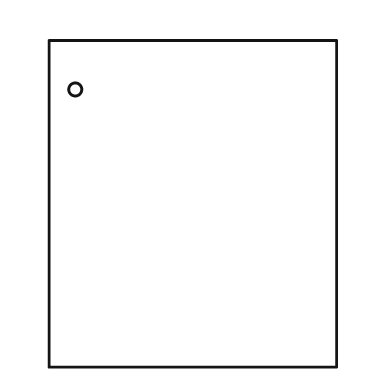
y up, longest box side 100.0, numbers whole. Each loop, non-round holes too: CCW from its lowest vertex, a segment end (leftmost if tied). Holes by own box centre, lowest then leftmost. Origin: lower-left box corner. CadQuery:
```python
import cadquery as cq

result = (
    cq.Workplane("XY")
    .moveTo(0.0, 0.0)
    .lineTo(88.0, 0.0)
    .lineTo(88.0, 100.0)
    .lineTo(0.0, 100.0)
    .close()
    .moveTo(8.0, 85.0)
    .circle(2.0)
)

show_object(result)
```